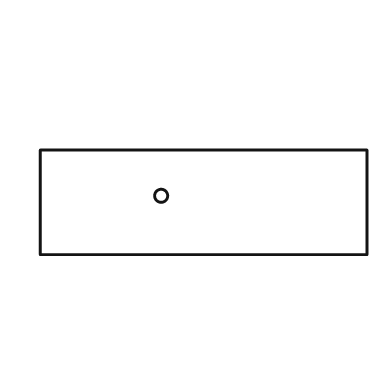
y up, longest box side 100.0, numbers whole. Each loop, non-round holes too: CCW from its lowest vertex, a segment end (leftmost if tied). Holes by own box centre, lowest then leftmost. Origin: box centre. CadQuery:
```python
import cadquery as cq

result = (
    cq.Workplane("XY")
    .moveTo(-50.0, -16.0)
    .lineTo(50.0, -16.0)
    .lineTo(50.0, 16.0)
    .lineTo(-50.0, 16.0)
    .close()
    .moveTo(-13.0, 2.0)
    .circle(2.0)
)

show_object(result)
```